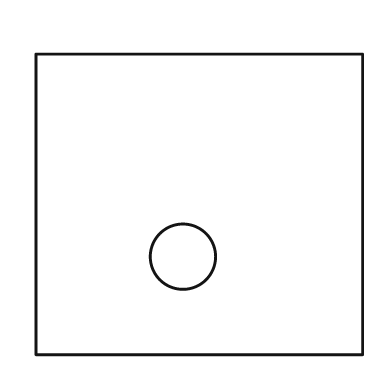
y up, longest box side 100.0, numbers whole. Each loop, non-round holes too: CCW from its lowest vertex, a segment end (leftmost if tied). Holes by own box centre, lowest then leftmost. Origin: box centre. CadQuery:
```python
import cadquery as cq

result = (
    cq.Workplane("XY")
    .moveTo(-50.0, -46.0)
    .lineTo(50.0, -46.0)
    .lineTo(50.0, 46.0)
    .lineTo(-50.0, 46.0)
    .close()
    .moveTo(-5.0, -16.0)
    .circle(10.0)
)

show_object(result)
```